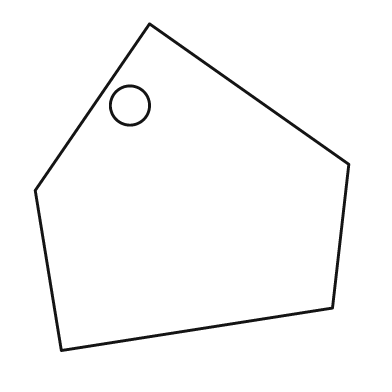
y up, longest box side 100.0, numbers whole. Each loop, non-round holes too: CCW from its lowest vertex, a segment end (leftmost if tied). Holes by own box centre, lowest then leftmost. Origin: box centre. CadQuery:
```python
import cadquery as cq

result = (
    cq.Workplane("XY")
    .moveTo(-40.0, -50.0)
    .lineTo(43.0, -37.0)
    .lineTo(48.0, 7.0)
    .lineTo(-13.0, 50.0)
    .lineTo(-48.0, -1.0)
    .close()
    .moveTo(-19.0, 25.0)
    .circle(6.0)
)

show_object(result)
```